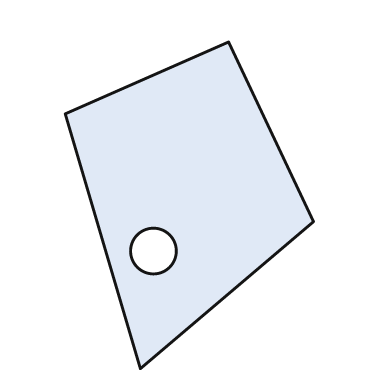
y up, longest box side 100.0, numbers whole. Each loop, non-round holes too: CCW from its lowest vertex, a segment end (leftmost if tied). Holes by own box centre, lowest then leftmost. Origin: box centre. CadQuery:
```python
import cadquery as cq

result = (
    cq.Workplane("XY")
    .moveTo(-15.0, -50.0)
    .lineTo(38.0, -5.0)
    .lineTo(12.0, 50.0)
    .lineTo(-38.0, 28.0)
    .close()
    .moveTo(-11.0, -14.0)
    .circle(7.0)
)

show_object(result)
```